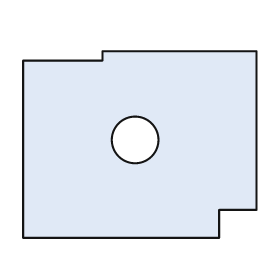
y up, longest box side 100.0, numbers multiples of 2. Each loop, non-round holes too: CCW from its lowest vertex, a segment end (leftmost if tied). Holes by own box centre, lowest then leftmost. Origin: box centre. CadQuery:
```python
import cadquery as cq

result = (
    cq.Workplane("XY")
    .moveTo(-50.0, -40.0)
    .lineTo(34.0, -40.0)
    .lineTo(34.0, -28.0)
    .lineTo(50.0, -28.0)
    .lineTo(50.0, 40.0)
    .lineTo(-16.0, 40.0)
    .lineTo(-16.0, 36.0)
    .lineTo(-50.0, 36.0)
    .close()
    .moveTo(-2.0, 2.0)
    .circle(10.0)
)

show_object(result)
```